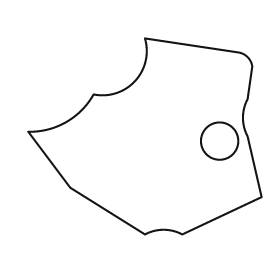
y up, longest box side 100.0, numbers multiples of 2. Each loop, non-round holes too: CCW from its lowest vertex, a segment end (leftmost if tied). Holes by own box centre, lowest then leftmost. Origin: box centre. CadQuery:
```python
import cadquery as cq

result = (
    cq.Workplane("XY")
    .moveTo(0.0, -42.0)
    .threePointArc((8.0, -40.0), (16.0, -42.0))
    .lineTo(50.0, -26.0)
    .lineTo(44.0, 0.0)
    .threePointArc((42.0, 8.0), (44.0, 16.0))
    .lineTo(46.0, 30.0)
    .threePointArc((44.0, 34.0), (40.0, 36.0))
    .lineTo(0.0, 42.0)
    .threePointArc((-4.0, 24.0), (-22.0, 18.0))
    .threePointArc((-34.0, 6.0), (-50.0, 2.0))
    .lineTo(-32.0, -22.0)
    .close()
    .moveTo(32.0, -2.0)
    .circle(8.0)
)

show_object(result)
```